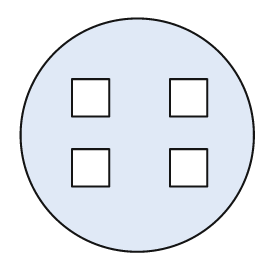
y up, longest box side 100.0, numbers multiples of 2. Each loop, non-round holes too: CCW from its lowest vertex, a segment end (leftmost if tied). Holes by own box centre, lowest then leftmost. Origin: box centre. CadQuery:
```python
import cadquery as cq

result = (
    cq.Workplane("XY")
    .moveTo(0.0, 0.0)
    .circle(50.0)
    .moveTo(-28.0, -22.0)
    .lineTo(-12.0, -22.0)
    .lineTo(-12.0, -6.0)
    .lineTo(-28.0, -6.0)
    .close()
    .moveTo(14.0, -22.0)
    .lineTo(30.0, -22.0)
    .lineTo(30.0, -6.0)
    .lineTo(14.0, -6.0)
    .close()
    .moveTo(-28.0, 8.0)
    .lineTo(-12.0, 8.0)
    .lineTo(-12.0, 24.0)
    .lineTo(-28.0, 24.0)
    .close()
    .moveTo(14.0, 8.0)
    .lineTo(30.0, 8.0)
    .lineTo(30.0, 24.0)
    .lineTo(14.0, 24.0)
    .close()
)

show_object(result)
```